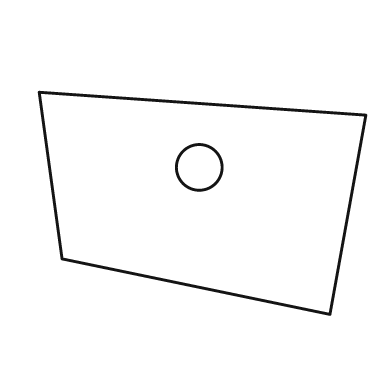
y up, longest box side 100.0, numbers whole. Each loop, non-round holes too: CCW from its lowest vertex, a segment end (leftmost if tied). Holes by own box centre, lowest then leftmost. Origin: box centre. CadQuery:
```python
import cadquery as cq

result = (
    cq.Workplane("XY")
    .moveTo(39.0, -34.0)
    .lineTo(50.0, 27.0)
    .lineTo(-50.0, 34.0)
    .lineTo(-43.0, -17.0)
    .close()
    .moveTo(-1.0, 11.0)
    .circle(7.0)
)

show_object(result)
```